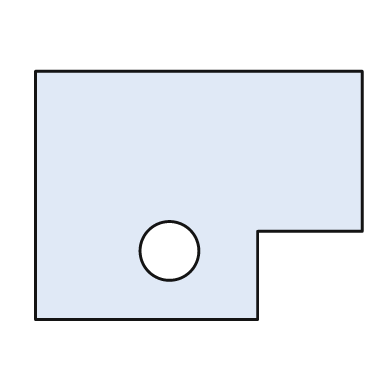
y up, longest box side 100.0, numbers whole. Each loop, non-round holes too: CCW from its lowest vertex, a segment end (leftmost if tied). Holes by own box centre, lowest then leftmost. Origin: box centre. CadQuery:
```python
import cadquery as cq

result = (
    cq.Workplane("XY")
    .moveTo(-50.0, -38.0)
    .lineTo(18.0, -38.0)
    .lineTo(18.0, -11.0)
    .lineTo(50.0, -11.0)
    .lineTo(50.0, 38.0)
    .lineTo(-50.0, 38.0)
    .close()
    .moveTo(-9.0, -17.0)
    .circle(9.0)
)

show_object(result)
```